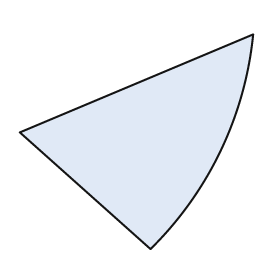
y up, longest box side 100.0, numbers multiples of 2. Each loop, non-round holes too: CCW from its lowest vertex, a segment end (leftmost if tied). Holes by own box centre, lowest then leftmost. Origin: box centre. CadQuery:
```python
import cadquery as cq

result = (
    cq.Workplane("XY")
    .moveTo(6.0, -46.0)
    .threePointArc((36.0, -4.0), (50.0, 46.0))
    .lineTo(-50.0, 4.0)
    .close()
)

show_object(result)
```